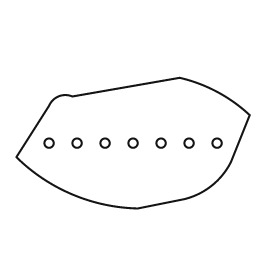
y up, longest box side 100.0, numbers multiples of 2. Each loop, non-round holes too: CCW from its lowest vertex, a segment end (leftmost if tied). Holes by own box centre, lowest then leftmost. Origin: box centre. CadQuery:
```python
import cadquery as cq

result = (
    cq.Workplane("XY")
    .moveTo(2.0, -28.0)
    .lineTo(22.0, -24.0)
    .threePointArc((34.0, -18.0), (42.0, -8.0))
    .lineTo(50.0, 12.0)
    .threePointArc((36.0, 22.0), (20.0, 28.0))
    .lineTo(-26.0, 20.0)
    .threePointArc((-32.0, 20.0), (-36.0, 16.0))
    .lineTo(-50.0, -6.0)
    .threePointArc((-26.0, -22.0), (2.0, -28.0))
    .close()
    .moveTo(-36.0, 0.0)
    .circle(2.0)
    .moveTo(-24.0, 0.0)
    .circle(2.0)
    .moveTo(-12.0, 0.0)
    .circle(2.0)
    .moveTo(0.0, 0.0)
    .circle(2.0)
    .moveTo(12.0, 0.0)
    .circle(2.0)
    .moveTo(24.0, 0.0)
    .circle(2.0)
    .moveTo(36.0, 0.0)
    .circle(2.0)
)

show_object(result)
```